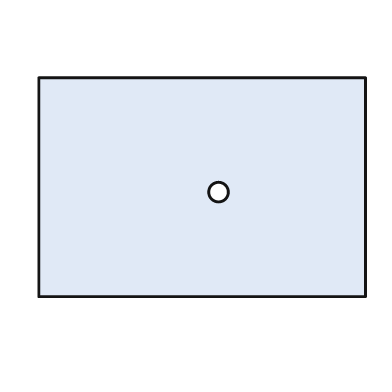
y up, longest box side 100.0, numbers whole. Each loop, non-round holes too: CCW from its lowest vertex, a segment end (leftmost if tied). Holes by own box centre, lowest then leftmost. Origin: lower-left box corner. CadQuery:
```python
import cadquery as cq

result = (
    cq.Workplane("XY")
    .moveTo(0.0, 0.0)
    .lineTo(100.0, 0.0)
    .lineTo(100.0, 67.0)
    .lineTo(0.0, 67.0)
    .close()
    .moveTo(55.0, 32.0)
    .circle(3.0)
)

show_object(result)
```